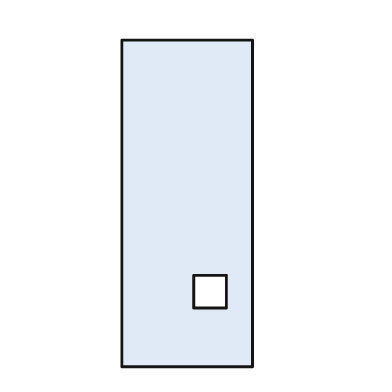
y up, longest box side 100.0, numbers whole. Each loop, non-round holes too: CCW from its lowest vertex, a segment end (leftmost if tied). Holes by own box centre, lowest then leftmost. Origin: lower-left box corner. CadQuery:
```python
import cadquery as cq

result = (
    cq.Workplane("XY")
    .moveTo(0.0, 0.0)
    .lineTo(40.0, 0.0)
    .lineTo(40.0, 100.0)
    .lineTo(0.0, 100.0)
    .close()
    .moveTo(22.0, 18.0)
    .lineTo(32.0, 18.0)
    .lineTo(32.0, 28.0)
    .lineTo(22.0, 28.0)
    .close()
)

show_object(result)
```